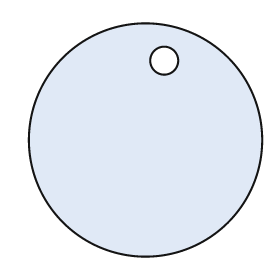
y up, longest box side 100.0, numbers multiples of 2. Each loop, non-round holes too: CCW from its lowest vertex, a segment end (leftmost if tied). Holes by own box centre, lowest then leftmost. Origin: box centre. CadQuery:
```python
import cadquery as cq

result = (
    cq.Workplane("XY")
    .moveTo(0.0, 0.0)
    .circle(50.0)
    .moveTo(8.0, 34.0)
    .circle(6.0)
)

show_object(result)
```